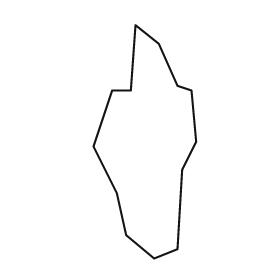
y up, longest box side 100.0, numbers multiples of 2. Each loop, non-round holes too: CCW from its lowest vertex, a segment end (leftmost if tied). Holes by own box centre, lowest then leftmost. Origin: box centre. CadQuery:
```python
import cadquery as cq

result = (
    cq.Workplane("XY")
    .moveTo(4.0, -50.0)
    .lineTo(14.0, -46.0)
    .lineTo(16.0, -12.0)
    .lineTo(22.0, 0.0)
    .lineTo(20.0, 22.0)
    .lineTo(14.0, 24.0)
    .lineTo(6.0, 42.0)
    .lineTo(-4.0, 50.0)
    .lineTo(-6.0, 22.0)
    .lineTo(-14.0, 22.0)
    .lineTo(-22.0, -2.0)
    .lineTo(-12.0, -22.0)
    .lineTo(-8.0, -40.0)
    .close()
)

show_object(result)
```